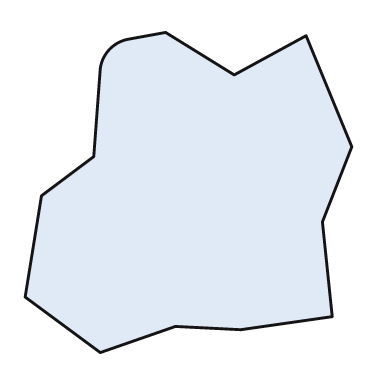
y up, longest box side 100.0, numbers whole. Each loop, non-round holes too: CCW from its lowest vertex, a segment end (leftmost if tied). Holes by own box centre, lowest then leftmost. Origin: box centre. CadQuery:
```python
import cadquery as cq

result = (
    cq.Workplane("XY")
    .moveTo(-27.0, -49.0)
    .lineTo(-4.0, -41.0)
    .lineTo(16.0, -42.0)
    .lineTo(44.0, -38.0)
    .lineTo(41.0, -9.0)
    .lineTo(50.0, 14.0)
    .lineTo(36.0, 48.0)
    .lineTo(14.0, 36.0)
    .lineTo(-7.0, 49.0)
    .lineTo(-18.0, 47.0)
    .threePointArc((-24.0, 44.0), (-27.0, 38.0))
    .lineTo(-29.0, 11.0)
    .lineTo(-45.0, -1.0)
    .lineTo(-50.0, -32.0)
    .close()
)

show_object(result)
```